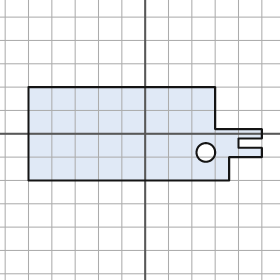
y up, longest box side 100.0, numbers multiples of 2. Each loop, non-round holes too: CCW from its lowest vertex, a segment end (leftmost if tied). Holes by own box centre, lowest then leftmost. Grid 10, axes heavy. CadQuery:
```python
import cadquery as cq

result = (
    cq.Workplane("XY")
    .moveTo(-50.0, -20.0)
    .lineTo(36.0, -20.0)
    .lineTo(36.0, -10.0)
    .lineTo(50.0, -10.0)
    .lineTo(50.0, -6.0)
    .lineTo(40.0, -6.0)
    .lineTo(40.0, -2.0)
    .lineTo(50.0, -2.0)
    .lineTo(50.0, 2.0)
    .lineTo(30.0, 2.0)
    .lineTo(30.0, 20.0)
    .lineTo(-50.0, 20.0)
    .close()
    .moveTo(26.0, -8.0)
    .circle(4.0)
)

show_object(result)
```